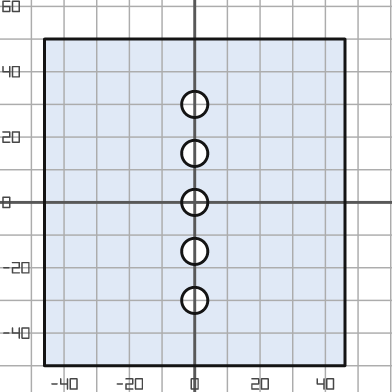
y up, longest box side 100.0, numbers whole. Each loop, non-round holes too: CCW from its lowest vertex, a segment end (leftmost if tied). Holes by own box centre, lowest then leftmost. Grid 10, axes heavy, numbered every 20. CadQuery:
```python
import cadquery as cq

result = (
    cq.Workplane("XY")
    .moveTo(-46.0, -50.0)
    .lineTo(46.0, -50.0)
    .lineTo(46.0, 50.0)
    .lineTo(-46.0, 50.0)
    .close()
    .moveTo(0.0, -30.0)
    .circle(4.0)
    .moveTo(0.0, -15.0)
    .circle(4.0)
    .moveTo(0.0, 0.0)
    .circle(4.0)
    .moveTo(0.0, 15.0)
    .circle(4.0)
    .moveTo(0.0, 30.0)
    .circle(4.0)
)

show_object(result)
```